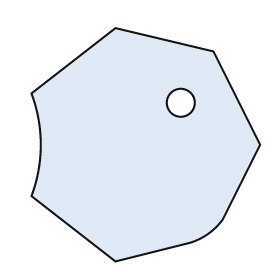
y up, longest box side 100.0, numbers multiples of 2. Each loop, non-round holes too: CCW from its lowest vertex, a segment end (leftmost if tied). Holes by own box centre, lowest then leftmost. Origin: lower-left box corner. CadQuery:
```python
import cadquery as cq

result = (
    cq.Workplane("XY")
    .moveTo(36.0, 0.0)
    .lineTo(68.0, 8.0)
    .threePointArc((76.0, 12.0), (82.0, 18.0))
    .lineTo(98.0, 50.0)
    .lineTo(78.0, 90.0)
    .lineTo(36.0, 100.0)
    .lineTo(0.0, 72.0)
    .threePointArc((4.0, 50.0), (0.0, 28.0))
    .close()
    .moveTo(64.0, 68.0)
    .circle(6.0)
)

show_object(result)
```